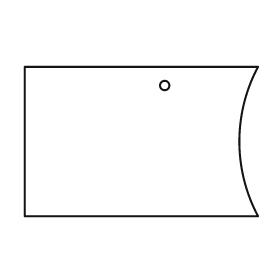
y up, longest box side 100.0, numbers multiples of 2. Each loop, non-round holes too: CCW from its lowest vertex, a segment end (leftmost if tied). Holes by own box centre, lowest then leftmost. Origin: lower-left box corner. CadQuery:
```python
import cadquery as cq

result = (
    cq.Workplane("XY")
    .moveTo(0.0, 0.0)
    .lineTo(100.0, 0.0)
    .threePointArc((92.0, 32.0), (100.0, 64.0))
    .lineTo(0.0, 64.0)
    .close()
    .moveTo(60.0, 56.0)
    .circle(2.0)
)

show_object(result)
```